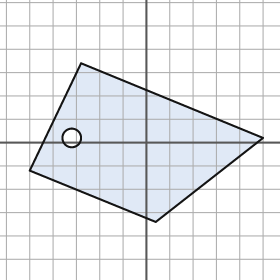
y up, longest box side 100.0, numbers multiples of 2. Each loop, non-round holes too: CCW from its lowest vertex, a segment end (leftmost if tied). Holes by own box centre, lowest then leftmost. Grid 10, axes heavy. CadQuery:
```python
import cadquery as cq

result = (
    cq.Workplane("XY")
    .moveTo(4.0, -34.0)
    .lineTo(50.0, 2.0)
    .lineTo(-28.0, 34.0)
    .lineTo(-50.0, -12.0)
    .close()
    .moveTo(-32.0, 2.0)
    .circle(4.0)
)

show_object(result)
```